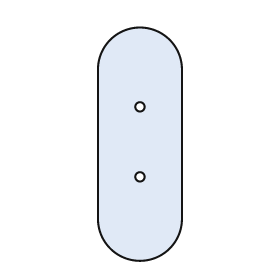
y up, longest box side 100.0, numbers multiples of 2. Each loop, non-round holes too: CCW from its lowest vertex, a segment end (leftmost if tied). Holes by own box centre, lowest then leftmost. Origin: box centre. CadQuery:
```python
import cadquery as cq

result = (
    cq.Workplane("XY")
    .moveTo(-18.0, -32.0)
    .threePointArc((0.0, -50.0), (18.0, -32.0))
    .lineTo(18.0, 32.0)
    .threePointArc((0.0, 50.0), (-18.0, 32.0))
    .close()
    .moveTo(0.0, -14.0)
    .circle(2.0)
    .moveTo(0.0, 16.0)
    .circle(2.0)
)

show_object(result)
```